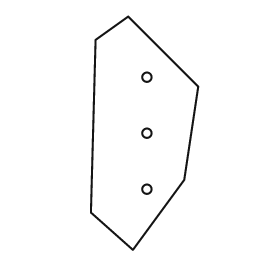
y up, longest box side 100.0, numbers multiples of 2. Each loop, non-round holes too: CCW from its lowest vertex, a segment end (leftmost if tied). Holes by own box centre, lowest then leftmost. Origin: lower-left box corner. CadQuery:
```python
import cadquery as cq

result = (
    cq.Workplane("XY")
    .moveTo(18.0, 0.0)
    .lineTo(40.0, 30.0)
    .lineTo(46.0, 70.0)
    .lineTo(16.0, 100.0)
    .lineTo(2.0, 90.0)
    .lineTo(0.0, 16.0)
    .close()
    .moveTo(24.0, 26.0)
    .circle(2.0)
    .moveTo(24.0, 50.0)
    .circle(2.0)
    .moveTo(24.0, 74.0)
    .circle(2.0)
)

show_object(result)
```